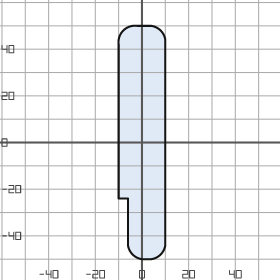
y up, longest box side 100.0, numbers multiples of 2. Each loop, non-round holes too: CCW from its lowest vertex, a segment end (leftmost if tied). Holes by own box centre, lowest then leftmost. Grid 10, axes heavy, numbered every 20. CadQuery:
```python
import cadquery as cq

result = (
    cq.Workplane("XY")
    .moveTo(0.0, -50.0)
    .lineTo(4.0, -50.0)
    .threePointArc((8.0, -48.0), (10.0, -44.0))
    .lineTo(10.0, 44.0)
    .threePointArc((8.0, 48.0), (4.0, 50.0))
    .lineTo(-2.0, 50.0)
    .threePointArc((-8.0, 48.0), (-10.0, 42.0))
    .lineTo(-10.0, -24.0)
    .lineTo(-6.0, -24.0)
    .lineTo(-6.0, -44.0)
    .threePointArc((-4.0, -48.0), (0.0, -50.0))
    .close()
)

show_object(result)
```